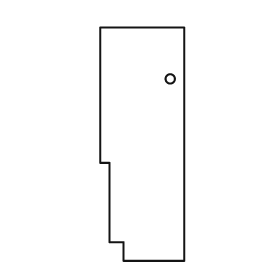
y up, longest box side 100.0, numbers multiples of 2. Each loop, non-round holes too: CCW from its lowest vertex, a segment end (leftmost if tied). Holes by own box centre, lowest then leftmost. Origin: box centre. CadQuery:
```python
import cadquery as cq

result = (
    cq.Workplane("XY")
    .moveTo(-8.0, -50.0)
    .lineTo(18.0, -50.0)
    .lineTo(18.0, 50.0)
    .lineTo(-18.0, 50.0)
    .lineTo(-18.0, -8.0)
    .lineTo(-14.0, -8.0)
    .lineTo(-14.0, -42.0)
    .lineTo(-8.0, -42.0)
    .close()
    .moveTo(12.0, 28.0)
    .circle(2.0)
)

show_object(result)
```